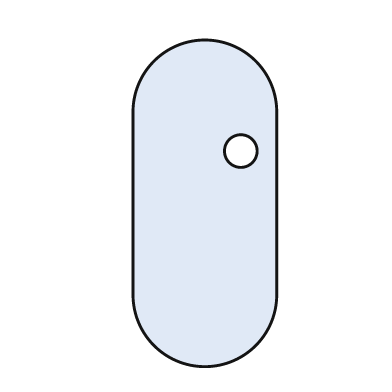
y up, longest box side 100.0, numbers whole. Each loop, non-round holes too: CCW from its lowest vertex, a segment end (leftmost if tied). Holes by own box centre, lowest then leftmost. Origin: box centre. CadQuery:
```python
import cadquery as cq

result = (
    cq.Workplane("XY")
    .moveTo(-22.0, -28.0)
    .threePointArc((0.0, -50.0), (22.0, -28.0))
    .lineTo(22.0, 28.0)
    .threePointArc((0.0, 50.0), (-22.0, 28.0))
    .close()
    .moveTo(11.0, 16.0)
    .circle(5.0)
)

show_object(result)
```